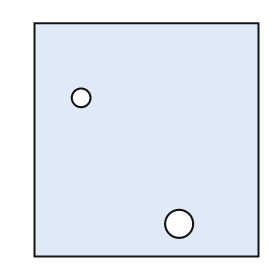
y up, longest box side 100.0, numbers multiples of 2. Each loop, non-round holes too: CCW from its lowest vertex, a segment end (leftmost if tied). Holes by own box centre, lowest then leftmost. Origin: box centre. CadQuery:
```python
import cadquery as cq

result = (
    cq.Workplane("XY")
    .moveTo(-48.0, -50.0)
    .lineTo(48.0, -50.0)
    .lineTo(48.0, 50.0)
    .lineTo(-48.0, 50.0)
    .close()
    .moveTo(14.0, -36.0)
    .circle(6.0)
    .moveTo(-28.0, 18.0)
    .circle(4.0)
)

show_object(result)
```